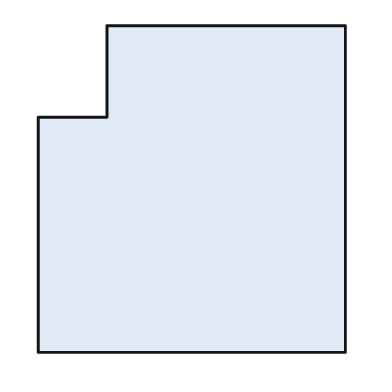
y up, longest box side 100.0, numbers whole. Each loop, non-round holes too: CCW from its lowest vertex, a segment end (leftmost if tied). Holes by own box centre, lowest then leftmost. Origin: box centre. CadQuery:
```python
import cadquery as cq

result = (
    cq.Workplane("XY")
    .moveTo(-47.0, -50.0)
    .lineTo(47.0, -50.0)
    .lineTo(47.0, 50.0)
    .lineTo(-26.0, 50.0)
    .lineTo(-26.0, 22.0)
    .lineTo(-47.0, 22.0)
    .close()
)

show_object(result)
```